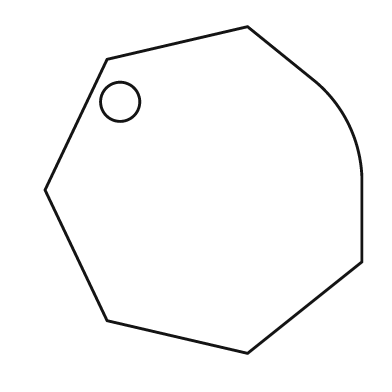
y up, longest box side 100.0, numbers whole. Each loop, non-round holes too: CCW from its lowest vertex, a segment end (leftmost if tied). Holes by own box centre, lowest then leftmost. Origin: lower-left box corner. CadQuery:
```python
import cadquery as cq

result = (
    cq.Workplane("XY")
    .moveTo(62.0, 0.0)
    .lineTo(97.0, 28.0)
    .lineTo(97.0, 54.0)
    .threePointArc((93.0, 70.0), (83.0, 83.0))
    .lineTo(62.0, 100.0)
    .lineTo(19.0, 90.0)
    .lineTo(0.0, 50.0)
    .lineTo(19.0, 10.0)
    .close()
    .moveTo(23.0, 77.0)
    .circle(6.0)
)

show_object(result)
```